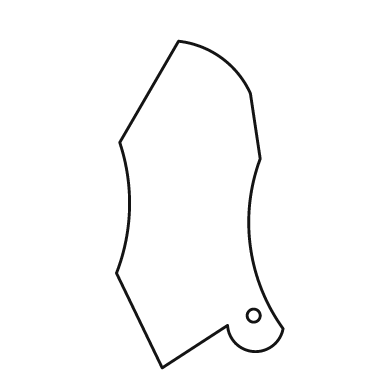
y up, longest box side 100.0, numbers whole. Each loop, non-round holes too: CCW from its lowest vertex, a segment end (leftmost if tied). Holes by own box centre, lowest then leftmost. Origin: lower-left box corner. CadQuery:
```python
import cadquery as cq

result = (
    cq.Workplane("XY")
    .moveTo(14.0, 0.0)
    .lineTo(34.0, 13.0)
    .threePointArc((42.0, 5.0), (51.0, 12.0))
    .threePointArc((41.0, 37.0), (44.0, 64.0))
    .lineTo(41.0, 84.0)
    .threePointArc((32.0, 95.0), (19.0, 100.0))
    .lineTo(1.0, 69.0)
    .threePointArc((4.0, 49.0), (0.0, 29.0))
    .close()
    .moveTo(42.0, 16.0)
    .circle(2.0)
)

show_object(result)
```